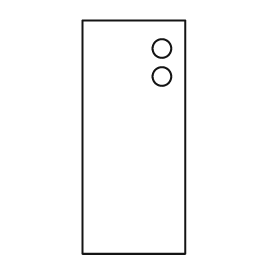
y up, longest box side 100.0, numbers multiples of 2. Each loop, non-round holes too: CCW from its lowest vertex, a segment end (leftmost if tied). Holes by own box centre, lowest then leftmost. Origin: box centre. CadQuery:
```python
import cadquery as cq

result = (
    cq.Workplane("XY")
    .moveTo(-22.0, -50.0)
    .lineTo(22.0, -50.0)
    .lineTo(22.0, 50.0)
    .lineTo(-22.0, 50.0)
    .close()
    .moveTo(12.0, 26.0)
    .circle(4.0)
    .moveTo(12.0, 38.0)
    .circle(4.0)
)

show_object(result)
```